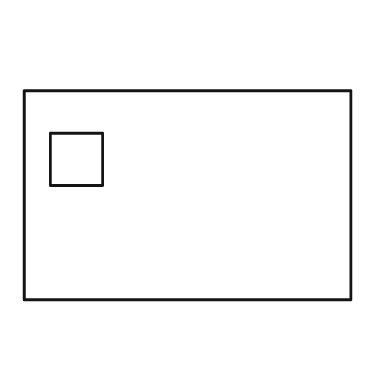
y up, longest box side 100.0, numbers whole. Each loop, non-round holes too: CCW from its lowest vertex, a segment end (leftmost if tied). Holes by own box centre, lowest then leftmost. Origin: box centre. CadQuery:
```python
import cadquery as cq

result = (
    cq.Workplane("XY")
    .moveTo(-50.0, -32.0)
    .lineTo(50.0, -32.0)
    .lineTo(50.0, 32.0)
    .lineTo(-50.0, 32.0)
    .close()
    .moveTo(-42.0, 3.0)
    .lineTo(-26.0, 3.0)
    .lineTo(-26.0, 19.0)
    .lineTo(-42.0, 19.0)
    .close()
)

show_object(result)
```